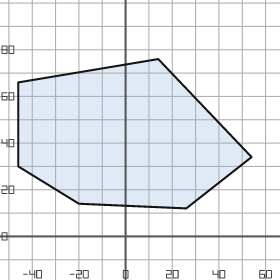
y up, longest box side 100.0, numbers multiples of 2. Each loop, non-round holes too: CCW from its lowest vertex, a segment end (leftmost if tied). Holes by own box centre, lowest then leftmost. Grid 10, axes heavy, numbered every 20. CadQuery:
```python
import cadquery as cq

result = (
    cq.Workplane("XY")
    .moveTo(26.0, 12.0)
    .lineTo(54.0, 34.0)
    .lineTo(14.0, 76.0)
    .lineTo(-46.0, 66.0)
    .lineTo(-46.0, 30.0)
    .lineTo(-20.0, 14.0)
    .close()
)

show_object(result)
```